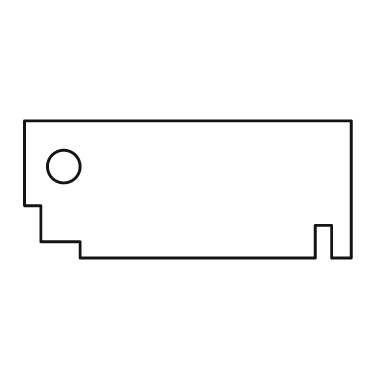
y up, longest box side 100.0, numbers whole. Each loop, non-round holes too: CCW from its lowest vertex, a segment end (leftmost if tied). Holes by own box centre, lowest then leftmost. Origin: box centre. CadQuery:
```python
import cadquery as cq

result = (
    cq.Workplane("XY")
    .moveTo(-33.0, -21.0)
    .lineTo(39.0, -21.0)
    .lineTo(39.0, -11.0)
    .lineTo(44.0, -11.0)
    .lineTo(44.0, -21.0)
    .lineTo(50.0, -21.0)
    .lineTo(50.0, 21.0)
    .lineTo(-50.0, 21.0)
    .lineTo(-50.0, -5.0)
    .lineTo(-45.0, -5.0)
    .lineTo(-45.0, -16.0)
    .lineTo(-33.0, -16.0)
    .close()
    .moveTo(-38.0, 7.0)
    .circle(5.0)
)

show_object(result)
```